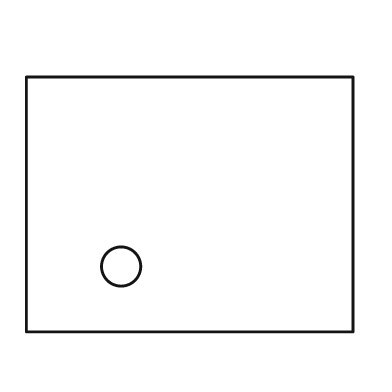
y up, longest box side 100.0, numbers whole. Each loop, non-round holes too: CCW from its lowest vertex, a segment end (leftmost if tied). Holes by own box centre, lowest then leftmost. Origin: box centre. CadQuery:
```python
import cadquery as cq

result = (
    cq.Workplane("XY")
    .moveTo(-50.0, -39.0)
    .lineTo(50.0, -39.0)
    .lineTo(50.0, 39.0)
    .lineTo(-50.0, 39.0)
    .close()
    .moveTo(-21.0, -19.0)
    .circle(6.0)
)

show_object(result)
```